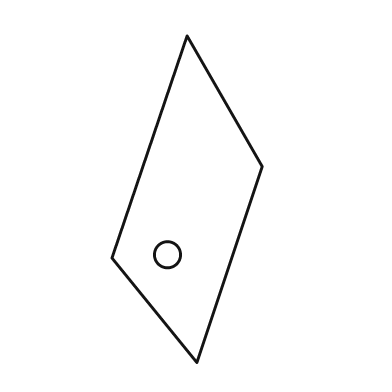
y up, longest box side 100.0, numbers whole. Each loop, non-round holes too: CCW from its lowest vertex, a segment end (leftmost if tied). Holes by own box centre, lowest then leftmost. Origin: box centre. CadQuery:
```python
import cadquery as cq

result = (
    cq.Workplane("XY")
    .moveTo(3.0, -50.0)
    .lineTo(23.0, 10.0)
    .lineTo(0.0, 50.0)
    .lineTo(-23.0, -18.0)
    .close()
    .moveTo(-6.0, -17.0)
    .circle(4.0)
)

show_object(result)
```